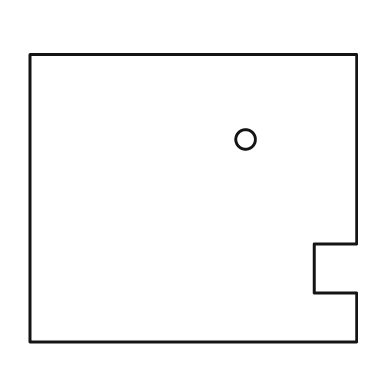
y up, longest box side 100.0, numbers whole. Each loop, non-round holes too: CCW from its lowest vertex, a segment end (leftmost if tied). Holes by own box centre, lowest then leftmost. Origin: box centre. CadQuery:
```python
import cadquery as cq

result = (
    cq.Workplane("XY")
    .moveTo(-50.0, -44.0)
    .lineTo(50.0, -44.0)
    .lineTo(50.0, -29.0)
    .lineTo(37.0, -29.0)
    .lineTo(37.0, -14.0)
    .lineTo(50.0, -14.0)
    .lineTo(50.0, 44.0)
    .lineTo(-50.0, 44.0)
    .close()
    .moveTo(16.0, 18.0)
    .circle(3.0)
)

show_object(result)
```